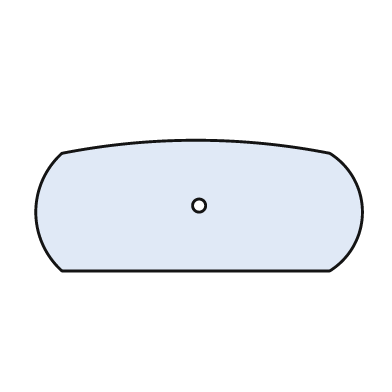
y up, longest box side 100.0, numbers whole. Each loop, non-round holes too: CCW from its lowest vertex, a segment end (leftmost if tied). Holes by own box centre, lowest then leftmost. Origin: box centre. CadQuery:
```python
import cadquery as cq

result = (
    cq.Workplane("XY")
    .moveTo(-42.0, -20.0)
    .lineTo(40.0, -20.0)
    .threePointArc((50.0, -2.0), (40.0, 16.0))
    .threePointArc((-1.0, 20.0), (-42.0, 16.0))
    .threePointArc((-50.0, -2.0), (-42.0, -20.0))
    .close()
    .moveTo(0.0, 0.0)
    .circle(2.0)
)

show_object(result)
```